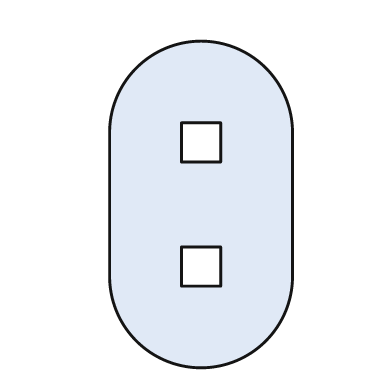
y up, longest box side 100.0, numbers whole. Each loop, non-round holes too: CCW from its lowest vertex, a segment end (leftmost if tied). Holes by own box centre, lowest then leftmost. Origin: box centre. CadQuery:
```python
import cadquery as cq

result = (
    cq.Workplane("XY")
    .moveTo(-28.0, -22.0)
    .threePointArc((0.0, -50.0), (28.0, -22.0))
    .lineTo(28.0, 22.0)
    .threePointArc((0.0, 50.0), (-28.0, 22.0))
    .close()
    .moveTo(-6.0, -25.0)
    .lineTo(6.0, -25.0)
    .lineTo(6.0, -13.0)
    .lineTo(-6.0, -13.0)
    .close()
    .moveTo(-6.0, 13.0)
    .lineTo(6.0, 13.0)
    .lineTo(6.0, 25.0)
    .lineTo(-6.0, 25.0)
    .close()
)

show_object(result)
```